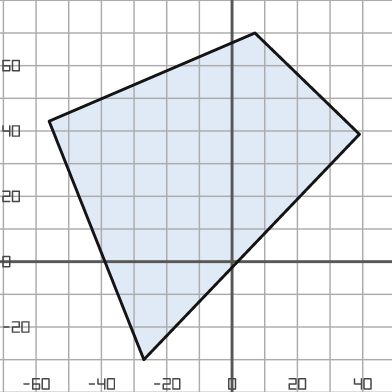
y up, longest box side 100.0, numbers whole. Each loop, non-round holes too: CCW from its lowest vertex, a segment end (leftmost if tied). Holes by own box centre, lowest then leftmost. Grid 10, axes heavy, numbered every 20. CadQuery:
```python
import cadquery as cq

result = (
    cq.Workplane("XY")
    .moveTo(-27.0, -30.0)
    .lineTo(39.0, 39.0)
    .lineTo(7.0, 70.0)
    .lineTo(-56.0, 43.0)
    .close()
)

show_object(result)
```